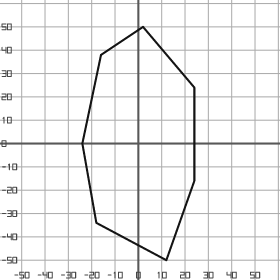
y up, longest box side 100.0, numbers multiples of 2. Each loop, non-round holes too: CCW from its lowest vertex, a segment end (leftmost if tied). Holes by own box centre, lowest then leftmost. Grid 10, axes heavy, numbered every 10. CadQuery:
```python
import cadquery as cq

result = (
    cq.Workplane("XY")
    .moveTo(12.0, -50.0)
    .lineTo(24.0, -16.0)
    .lineTo(24.0, 24.0)
    .lineTo(2.0, 50.0)
    .lineTo(-16.0, 38.0)
    .lineTo(-24.0, 0.0)
    .lineTo(-18.0, -34.0)
    .close()
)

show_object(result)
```